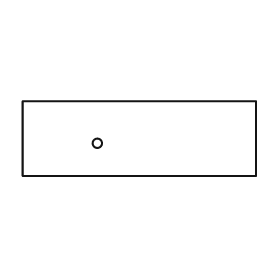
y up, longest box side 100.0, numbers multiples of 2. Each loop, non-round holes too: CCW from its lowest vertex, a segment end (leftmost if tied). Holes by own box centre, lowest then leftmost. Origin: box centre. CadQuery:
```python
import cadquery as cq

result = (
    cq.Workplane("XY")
    .moveTo(-50.0, -16.0)
    .lineTo(50.0, -16.0)
    .lineTo(50.0, 16.0)
    .lineTo(-50.0, 16.0)
    .close()
    .moveTo(-18.0, -2.0)
    .circle(2.0)
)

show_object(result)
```